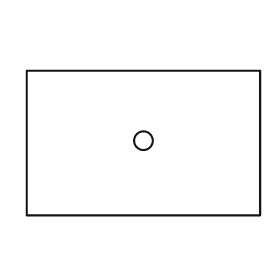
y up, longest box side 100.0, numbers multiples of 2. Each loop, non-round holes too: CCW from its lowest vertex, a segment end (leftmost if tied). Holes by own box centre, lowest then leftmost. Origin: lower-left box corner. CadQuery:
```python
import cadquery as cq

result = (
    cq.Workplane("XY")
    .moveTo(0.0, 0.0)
    .lineTo(100.0, 0.0)
    .lineTo(100.0, 62.0)
    .lineTo(0.0, 62.0)
    .close()
    .moveTo(50.0, 32.0)
    .circle(4.0)
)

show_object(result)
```